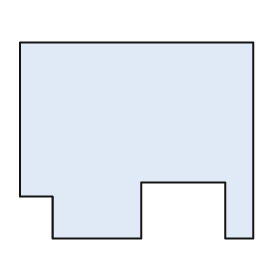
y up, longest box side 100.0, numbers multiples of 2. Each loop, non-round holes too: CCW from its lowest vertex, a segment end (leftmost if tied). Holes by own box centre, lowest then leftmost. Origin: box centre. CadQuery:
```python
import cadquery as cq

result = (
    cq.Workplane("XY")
    .moveTo(-36.0, -42.0)
    .lineTo(2.0, -42.0)
    .lineTo(2.0, -18.0)
    .lineTo(38.0, -18.0)
    .lineTo(38.0, -42.0)
    .lineTo(50.0, -42.0)
    .lineTo(50.0, 42.0)
    .lineTo(-50.0, 42.0)
    .lineTo(-50.0, -24.0)
    .lineTo(-36.0, -24.0)
    .close()
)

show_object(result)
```